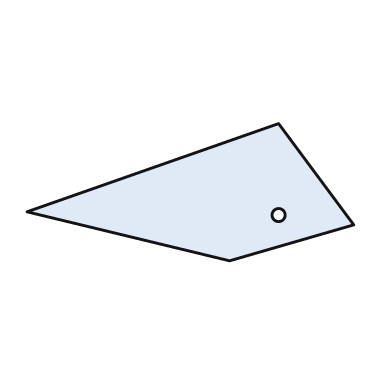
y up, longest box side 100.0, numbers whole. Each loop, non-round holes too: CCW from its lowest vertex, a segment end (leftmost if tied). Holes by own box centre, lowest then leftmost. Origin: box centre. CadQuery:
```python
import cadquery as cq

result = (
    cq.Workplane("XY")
    .moveTo(12.0, -21.0)
    .lineTo(50.0, -10.0)
    .lineTo(27.0, 21.0)
    .lineTo(-50.0, -6.0)
    .close()
    .moveTo(27.0, -7.0)
    .circle(2.0)
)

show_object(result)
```